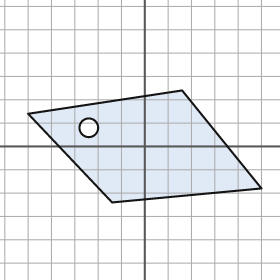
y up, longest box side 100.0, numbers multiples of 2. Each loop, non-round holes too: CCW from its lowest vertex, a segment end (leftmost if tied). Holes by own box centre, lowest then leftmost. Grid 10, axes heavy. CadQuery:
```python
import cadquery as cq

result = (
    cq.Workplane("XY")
    .moveTo(-14.0, -24.0)
    .lineTo(50.0, -18.0)
    .lineTo(16.0, 24.0)
    .lineTo(-50.0, 14.0)
    .close()
    .moveTo(-24.0, 8.0)
    .circle(4.0)
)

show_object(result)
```